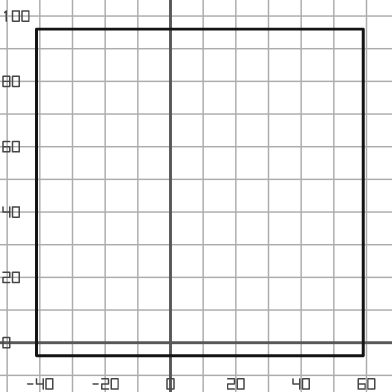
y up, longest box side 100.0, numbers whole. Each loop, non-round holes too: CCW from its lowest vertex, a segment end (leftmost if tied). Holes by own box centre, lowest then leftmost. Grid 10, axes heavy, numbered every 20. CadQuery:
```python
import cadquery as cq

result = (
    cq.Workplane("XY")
    .moveTo(-41.0, -4.0)
    .lineTo(59.0, -4.0)
    .lineTo(59.0, 96.0)
    .lineTo(-41.0, 96.0)
    .close()
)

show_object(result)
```